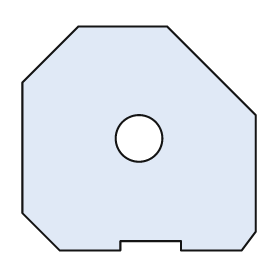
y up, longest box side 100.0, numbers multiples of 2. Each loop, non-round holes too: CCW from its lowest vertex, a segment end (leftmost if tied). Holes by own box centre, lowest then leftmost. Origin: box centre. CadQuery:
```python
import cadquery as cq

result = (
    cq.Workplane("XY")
    .moveTo(-34.0, -48.0)
    .lineTo(-8.0, -48.0)
    .lineTo(-8.0, -44.0)
    .lineTo(18.0, -44.0)
    .lineTo(18.0, -48.0)
    .lineTo(44.0, -48.0)
    .lineTo(50.0, -40.0)
    .lineTo(50.0, 10.0)
    .lineTo(12.0, 48.0)
    .lineTo(-26.0, 48.0)
    .lineTo(-50.0, 24.0)
    .lineTo(-50.0, -32.0)
    .close()
    .moveTo(0.0, 0.0)
    .circle(10.0)
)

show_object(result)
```